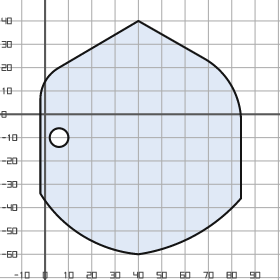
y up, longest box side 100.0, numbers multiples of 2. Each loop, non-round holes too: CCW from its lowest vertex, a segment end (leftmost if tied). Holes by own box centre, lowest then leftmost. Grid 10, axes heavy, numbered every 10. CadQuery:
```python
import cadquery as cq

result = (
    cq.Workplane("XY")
    .moveTo(40.0, -60.0)
    .threePointArc((64.0, -52.0), (84.0, -36.0))
    .lineTo(84.0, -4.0)
    .threePointArc((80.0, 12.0), (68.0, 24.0))
    .lineTo(40.0, 40.0)
    .lineTo(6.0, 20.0)
    .threePointArc((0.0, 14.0), (-2.0, 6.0))
    .lineTo(-2.0, -34.0)
    .threePointArc((16.0, -52.0), (40.0, -60.0))
    .close()
    .moveTo(6.0, -10.0)
    .circle(4.0)
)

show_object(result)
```